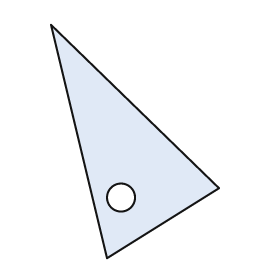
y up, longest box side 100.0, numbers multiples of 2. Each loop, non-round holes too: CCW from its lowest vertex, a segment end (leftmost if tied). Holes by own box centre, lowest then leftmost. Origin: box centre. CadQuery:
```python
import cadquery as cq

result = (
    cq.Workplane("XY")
    .moveTo(-12.0, -50.0)
    .lineTo(36.0, -20.0)
    .lineTo(-36.0, 50.0)
    .close()
    .moveTo(-6.0, -24.0)
    .circle(6.0)
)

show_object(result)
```